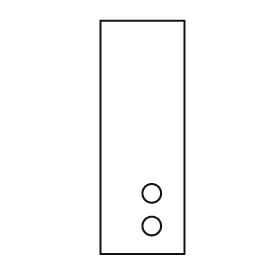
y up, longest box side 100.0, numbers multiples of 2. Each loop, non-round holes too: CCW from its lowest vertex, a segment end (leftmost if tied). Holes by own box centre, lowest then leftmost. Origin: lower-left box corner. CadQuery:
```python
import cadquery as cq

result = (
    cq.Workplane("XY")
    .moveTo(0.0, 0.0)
    .lineTo(36.0, 0.0)
    .lineTo(36.0, 100.0)
    .lineTo(0.0, 100.0)
    .close()
    .moveTo(22.0, 12.0)
    .circle(4.0)
    .moveTo(22.0, 26.0)
    .circle(4.0)
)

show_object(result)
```